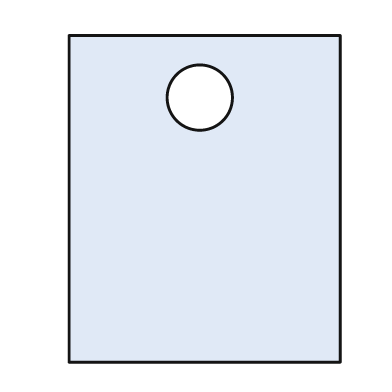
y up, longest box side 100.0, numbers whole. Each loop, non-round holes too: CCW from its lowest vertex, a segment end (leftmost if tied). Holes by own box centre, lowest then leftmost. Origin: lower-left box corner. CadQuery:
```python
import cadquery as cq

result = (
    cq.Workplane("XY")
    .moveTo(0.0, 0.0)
    .lineTo(83.0, 0.0)
    .lineTo(83.0, 100.0)
    .lineTo(0.0, 100.0)
    .close()
    .moveTo(40.0, 81.0)
    .circle(10.0)
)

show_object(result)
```